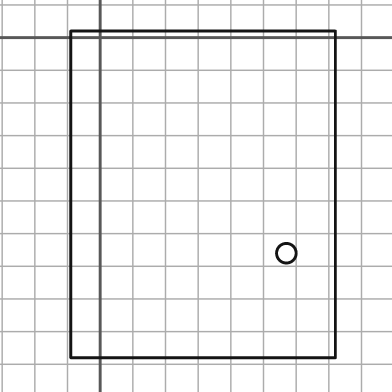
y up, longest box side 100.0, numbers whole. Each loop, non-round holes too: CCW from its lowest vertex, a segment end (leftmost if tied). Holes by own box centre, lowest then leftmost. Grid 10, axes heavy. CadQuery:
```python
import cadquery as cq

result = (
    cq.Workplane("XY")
    .moveTo(-9.0, -98.0)
    .lineTo(72.0, -98.0)
    .lineTo(72.0, 2.0)
    .lineTo(-9.0, 2.0)
    .close()
    .moveTo(57.0, -66.0)
    .circle(3.0)
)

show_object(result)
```